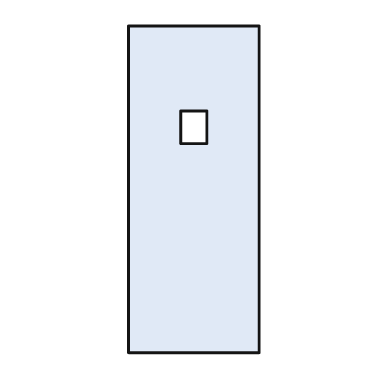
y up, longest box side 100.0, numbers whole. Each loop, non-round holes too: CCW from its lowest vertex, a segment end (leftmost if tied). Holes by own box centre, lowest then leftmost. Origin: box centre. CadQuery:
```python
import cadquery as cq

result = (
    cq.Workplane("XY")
    .moveTo(-20.0, -50.0)
    .lineTo(20.0, -50.0)
    .lineTo(20.0, 50.0)
    .lineTo(-20.0, 50.0)
    .close()
    .moveTo(-4.0, 14.0)
    .lineTo(4.0, 14.0)
    .lineTo(4.0, 24.0)
    .lineTo(-4.0, 24.0)
    .close()
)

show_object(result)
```